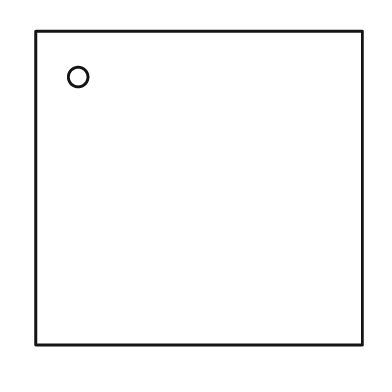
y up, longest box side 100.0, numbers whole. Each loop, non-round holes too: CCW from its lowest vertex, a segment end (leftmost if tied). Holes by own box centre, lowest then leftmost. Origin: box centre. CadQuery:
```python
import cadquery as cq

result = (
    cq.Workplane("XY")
    .moveTo(-50.0, -48.0)
    .lineTo(50.0, -48.0)
    .lineTo(50.0, 48.0)
    .lineTo(-50.0, 48.0)
    .close()
    .moveTo(-37.0, 34.0)
    .circle(3.0)
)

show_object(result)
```